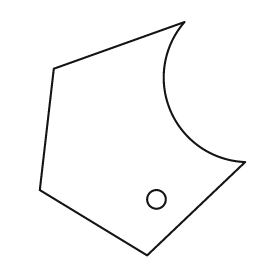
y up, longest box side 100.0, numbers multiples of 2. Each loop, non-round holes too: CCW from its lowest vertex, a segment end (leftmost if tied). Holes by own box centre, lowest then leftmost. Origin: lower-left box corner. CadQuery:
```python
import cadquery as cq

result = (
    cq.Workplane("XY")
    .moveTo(46.0, 0.0)
    .lineTo(88.0, 40.0)
    .threePointArc((56.0, 62.0), (62.0, 100.0))
    .lineTo(6.0, 80.0)
    .lineTo(0.0, 28.0)
    .close()
    .moveTo(50.0, 24.0)
    .circle(4.0)
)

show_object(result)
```